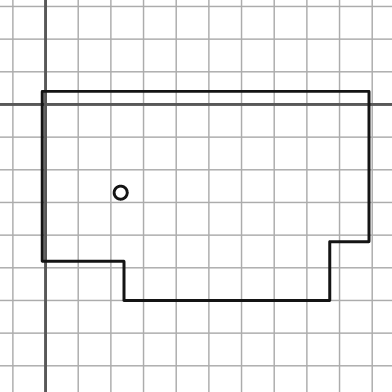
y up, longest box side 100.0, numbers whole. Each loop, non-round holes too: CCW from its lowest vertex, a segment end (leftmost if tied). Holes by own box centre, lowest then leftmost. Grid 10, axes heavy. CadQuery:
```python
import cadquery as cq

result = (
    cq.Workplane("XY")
    .moveTo(24.0, -60.0)
    .lineTo(87.0, -60.0)
    .lineTo(87.0, -42.0)
    .lineTo(99.0, -42.0)
    .lineTo(99.0, 4.0)
    .lineTo(-1.0, 4.0)
    .lineTo(-1.0, -48.0)
    .lineTo(24.0, -48.0)
    .close()
    .moveTo(23.0, -27.0)
    .circle(2.0)
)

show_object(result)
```